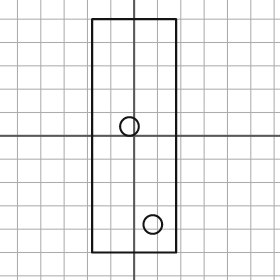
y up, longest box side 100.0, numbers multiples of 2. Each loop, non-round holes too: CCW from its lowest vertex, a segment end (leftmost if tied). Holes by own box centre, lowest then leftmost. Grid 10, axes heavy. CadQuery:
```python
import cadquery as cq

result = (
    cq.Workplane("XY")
    .moveTo(-18.0, -50.0)
    .lineTo(18.0, -50.0)
    .lineTo(18.0, 50.0)
    .lineTo(-18.0, 50.0)
    .close()
    .moveTo(8.0, -38.0)
    .circle(4.0)
    .moveTo(-2.0, 4.0)
    .circle(4.0)
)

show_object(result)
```